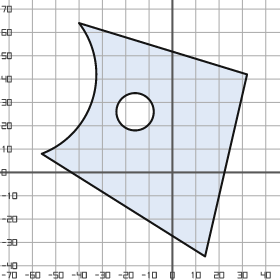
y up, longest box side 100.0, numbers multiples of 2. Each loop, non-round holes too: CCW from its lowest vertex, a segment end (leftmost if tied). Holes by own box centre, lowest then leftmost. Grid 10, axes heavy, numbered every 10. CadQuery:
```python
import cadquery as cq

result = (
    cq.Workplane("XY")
    .moveTo(14.0, -36.0)
    .lineTo(32.0, 42.0)
    .lineTo(-40.0, 64.0)
    .threePointArc((-34.0, 32.0), (-56.0, 8.0))
    .close()
    .moveTo(-16.0, 26.0)
    .circle(8.0)
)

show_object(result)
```